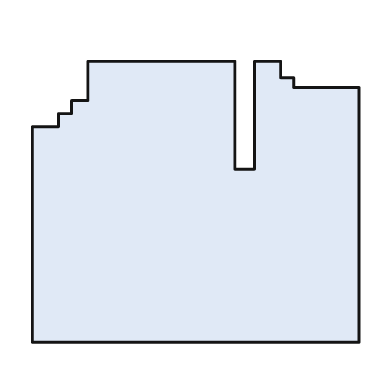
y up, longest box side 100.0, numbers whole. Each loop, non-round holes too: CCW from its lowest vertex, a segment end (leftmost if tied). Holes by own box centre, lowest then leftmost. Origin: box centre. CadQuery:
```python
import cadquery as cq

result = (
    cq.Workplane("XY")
    .moveTo(-50.0, -43.0)
    .lineTo(50.0, -43.0)
    .lineTo(50.0, 35.0)
    .lineTo(30.0, 35.0)
    .lineTo(30.0, 38.0)
    .lineTo(26.0, 38.0)
    .lineTo(26.0, 43.0)
    .lineTo(18.0, 43.0)
    .lineTo(18.0, 10.0)
    .lineTo(12.0, 10.0)
    .lineTo(12.0, 43.0)
    .lineTo(-33.0, 43.0)
    .lineTo(-33.0, 31.0)
    .lineTo(-38.0, 31.0)
    .lineTo(-38.0, 27.0)
    .lineTo(-42.0, 27.0)
    .lineTo(-42.0, 23.0)
    .lineTo(-50.0, 23.0)
    .close()
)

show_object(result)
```